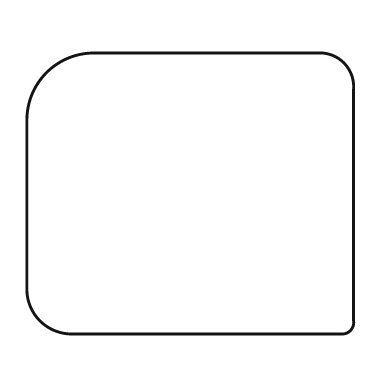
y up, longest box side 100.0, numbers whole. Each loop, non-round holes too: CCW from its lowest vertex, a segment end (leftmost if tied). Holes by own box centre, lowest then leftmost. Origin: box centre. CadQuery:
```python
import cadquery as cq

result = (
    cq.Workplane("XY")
    .moveTo(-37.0, -43.0)
    .lineTo(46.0, -43.0)
    .threePointArc((49.0, -42.0), (50.0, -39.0))
    .lineTo(50.0, 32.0)
    .threePointArc((47.0, 40.0), (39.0, 43.0))
    .lineTo(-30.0, 43.0)
    .threePointArc((-44.0, 37.0), (-50.0, 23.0))
    .lineTo(-50.0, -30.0)
    .threePointArc((-46.0, -39.0), (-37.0, -43.0))
    .close()
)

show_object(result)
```